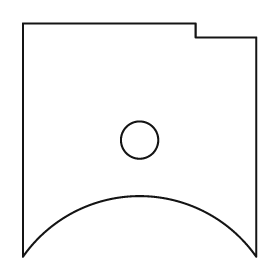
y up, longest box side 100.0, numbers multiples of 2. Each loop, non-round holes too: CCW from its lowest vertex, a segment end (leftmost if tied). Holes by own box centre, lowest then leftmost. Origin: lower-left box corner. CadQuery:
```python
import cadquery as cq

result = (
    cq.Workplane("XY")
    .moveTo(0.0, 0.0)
    .threePointArc((50.0, 26.0), (100.0, 0.0))
    .lineTo(100.0, 94.0)
    .lineTo(74.0, 94.0)
    .lineTo(74.0, 100.0)
    .lineTo(0.0, 100.0)
    .close()
    .moveTo(50.0, 50.0)
    .circle(8.0)
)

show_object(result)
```